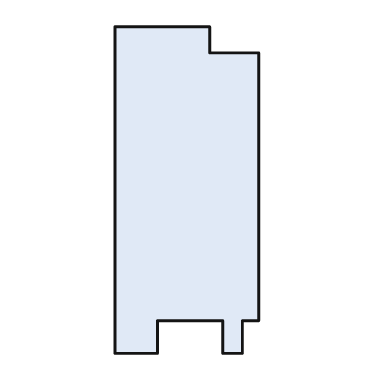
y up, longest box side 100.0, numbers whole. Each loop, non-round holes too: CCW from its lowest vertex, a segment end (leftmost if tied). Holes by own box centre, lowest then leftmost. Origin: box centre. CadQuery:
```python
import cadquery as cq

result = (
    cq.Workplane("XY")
    .moveTo(-22.0, -50.0)
    .lineTo(-9.0, -50.0)
    .lineTo(-9.0, -40.0)
    .lineTo(11.0, -40.0)
    .lineTo(11.0, -50.0)
    .lineTo(17.0, -50.0)
    .lineTo(17.0, -40.0)
    .lineTo(22.0, -40.0)
    .lineTo(22.0, 42.0)
    .lineTo(7.0, 42.0)
    .lineTo(7.0, 50.0)
    .lineTo(-22.0, 50.0)
    .close()
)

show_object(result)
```